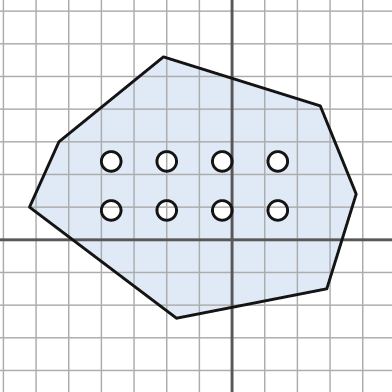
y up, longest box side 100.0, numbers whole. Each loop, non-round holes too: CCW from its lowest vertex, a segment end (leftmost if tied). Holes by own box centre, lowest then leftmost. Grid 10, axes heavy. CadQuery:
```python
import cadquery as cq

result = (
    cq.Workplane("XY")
    .moveTo(-17.0, -24.0)
    .lineTo(29.0, -15.0)
    .lineTo(38.0, 14.0)
    .lineTo(27.0, 41.0)
    .lineTo(-21.0, 56.0)
    .lineTo(-53.0, 30.0)
    .lineTo(-62.0, 10.0)
    .close()
    .moveTo(-37.0, 9.0)
    .circle(3.0)
    .moveTo(-20.0, 9.0)
    .circle(3.0)
    .moveTo(-3.0, 9.0)
    .circle(3.0)
    .moveTo(14.0, 9.0)
    .circle(3.0)
    .moveTo(-37.0, 24.0)
    .circle(3.0)
    .moveTo(-20.0, 24.0)
    .circle(3.0)
    .moveTo(-3.0, 24.0)
    .circle(3.0)
    .moveTo(14.0, 24.0)
    .circle(3.0)
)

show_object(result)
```